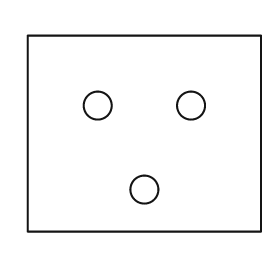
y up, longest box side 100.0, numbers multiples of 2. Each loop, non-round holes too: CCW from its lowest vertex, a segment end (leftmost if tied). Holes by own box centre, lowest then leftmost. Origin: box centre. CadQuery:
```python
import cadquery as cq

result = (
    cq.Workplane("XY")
    .moveTo(-50.0, -42.0)
    .lineTo(50.0, -42.0)
    .lineTo(50.0, 42.0)
    .lineTo(-50.0, 42.0)
    .close()
    .moveTo(0.0, -24.0)
    .circle(6.0)
    .moveTo(-20.0, 12.0)
    .circle(6.0)
    .moveTo(20.0, 12.0)
    .circle(6.0)
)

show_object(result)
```